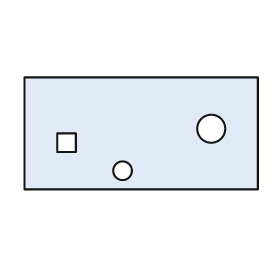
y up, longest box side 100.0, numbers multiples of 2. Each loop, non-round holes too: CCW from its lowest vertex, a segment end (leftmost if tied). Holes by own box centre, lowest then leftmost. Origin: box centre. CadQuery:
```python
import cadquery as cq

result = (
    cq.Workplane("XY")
    .moveTo(-50.0, -24.0)
    .lineTo(50.0, -24.0)
    .lineTo(50.0, 24.0)
    .lineTo(-50.0, 24.0)
    .close()
    .moveTo(-8.0, -16.0)
    .circle(4.0)
    .moveTo(-36.0, -8.0)
    .lineTo(-28.0, -8.0)
    .lineTo(-28.0, 0.0)
    .lineTo(-36.0, 0.0)
    .close()
    .moveTo(30.0, 2.0)
    .circle(6.0)
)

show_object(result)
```